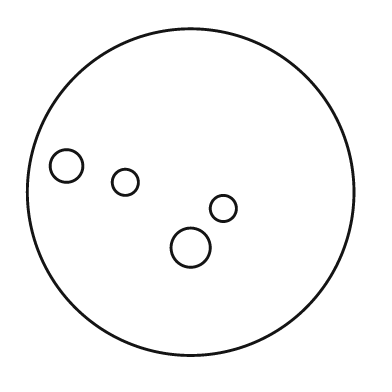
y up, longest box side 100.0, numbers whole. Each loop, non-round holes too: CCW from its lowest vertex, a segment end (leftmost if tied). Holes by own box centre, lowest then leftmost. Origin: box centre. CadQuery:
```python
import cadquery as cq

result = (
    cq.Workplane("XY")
    .moveTo(0.0, 0.0)
    .circle(50.0)
    .moveTo(0.0, -17.0)
    .circle(6.0)
    .moveTo(10.0, -5.0)
    .circle(4.0)
    .moveTo(-20.0, 3.0)
    .circle(4.0)
    .moveTo(-38.0, 8.0)
    .circle(5.0)
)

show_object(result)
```